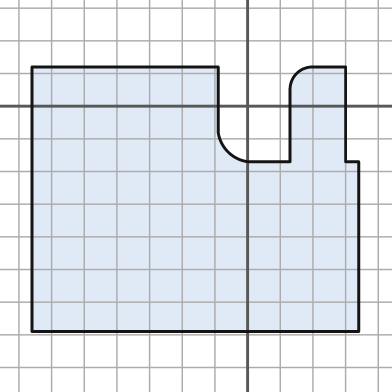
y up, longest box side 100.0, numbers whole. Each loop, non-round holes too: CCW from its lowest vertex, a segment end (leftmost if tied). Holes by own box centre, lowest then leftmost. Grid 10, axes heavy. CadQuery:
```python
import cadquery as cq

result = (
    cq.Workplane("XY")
    .moveTo(-66.0, -69.0)
    .lineTo(34.0, -69.0)
    .lineTo(34.0, -17.0)
    .lineTo(30.0, -17.0)
    .lineTo(30.0, 12.0)
    .lineTo(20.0, 12.0)
    .threePointArc((15.0, 10.0), (13.0, 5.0))
    .lineTo(13.0, -17.0)
    .lineTo(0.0, -17.0)
    .threePointArc((-6.0, -14.0), (-9.0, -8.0))
    .lineTo(-9.0, 12.0)
    .lineTo(-66.0, 12.0)
    .close()
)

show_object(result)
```